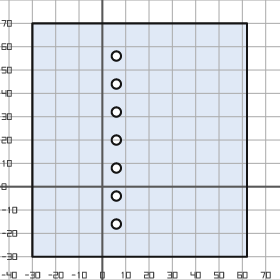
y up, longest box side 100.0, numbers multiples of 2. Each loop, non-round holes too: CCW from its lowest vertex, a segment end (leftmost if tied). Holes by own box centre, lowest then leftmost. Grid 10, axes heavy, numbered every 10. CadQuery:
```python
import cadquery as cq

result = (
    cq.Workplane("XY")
    .moveTo(-30.0, -30.0)
    .lineTo(62.0, -30.0)
    .lineTo(62.0, 70.0)
    .lineTo(-30.0, 70.0)
    .close()
    .moveTo(6.0, -16.0)
    .circle(2.0)
    .moveTo(6.0, -4.0)
    .circle(2.0)
    .moveTo(6.0, 8.0)
    .circle(2.0)
    .moveTo(6.0, 20.0)
    .circle(2.0)
    .moveTo(6.0, 32.0)
    .circle(2.0)
    .moveTo(6.0, 44.0)
    .circle(2.0)
    .moveTo(6.0, 56.0)
    .circle(2.0)
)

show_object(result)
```